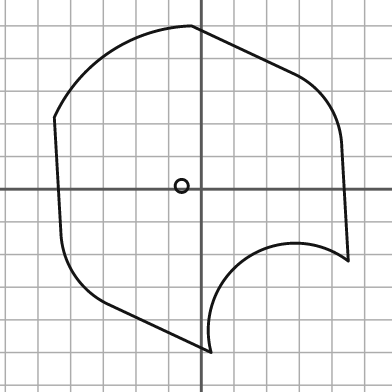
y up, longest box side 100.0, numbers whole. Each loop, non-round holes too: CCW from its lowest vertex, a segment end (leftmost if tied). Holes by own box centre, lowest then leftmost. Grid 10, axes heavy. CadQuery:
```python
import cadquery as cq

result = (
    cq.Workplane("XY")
    .moveTo(3.0, -50.0)
    .threePointArc((14.0, -21.0), (45.0, -22.0))
    .lineTo(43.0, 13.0)
    .threePointArc((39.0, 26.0), (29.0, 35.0))
    .lineTo(-3.0, 50.0)
    .threePointArc((-28.0, 42.0), (-45.0, 22.0))
    .lineTo(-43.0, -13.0)
    .threePointArc((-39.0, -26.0), (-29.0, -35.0))
    .close()
    .moveTo(-6.0, 1.0)
    .circle(2.0)
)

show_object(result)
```